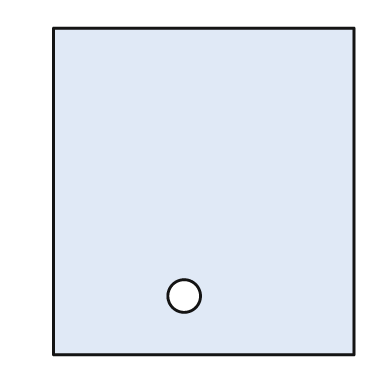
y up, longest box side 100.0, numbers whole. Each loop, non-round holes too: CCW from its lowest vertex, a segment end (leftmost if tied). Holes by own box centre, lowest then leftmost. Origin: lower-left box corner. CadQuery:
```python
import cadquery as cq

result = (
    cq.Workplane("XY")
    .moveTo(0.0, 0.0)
    .lineTo(92.0, 0.0)
    .lineTo(92.0, 100.0)
    .lineTo(0.0, 100.0)
    .close()
    .moveTo(40.0, 18.0)
    .circle(5.0)
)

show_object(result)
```